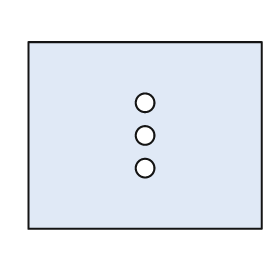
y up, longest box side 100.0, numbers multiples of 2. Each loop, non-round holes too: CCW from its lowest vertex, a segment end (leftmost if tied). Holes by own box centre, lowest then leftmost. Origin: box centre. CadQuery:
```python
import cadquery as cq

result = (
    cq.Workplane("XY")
    .moveTo(-50.0, -40.0)
    .lineTo(50.0, -40.0)
    .lineTo(50.0, 40.0)
    .lineTo(-50.0, 40.0)
    .close()
    .moveTo(0.0, -14.0)
    .circle(4.0)
    .moveTo(0.0, 0.0)
    .circle(4.0)
    .moveTo(0.0, 14.0)
    .circle(4.0)
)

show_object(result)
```